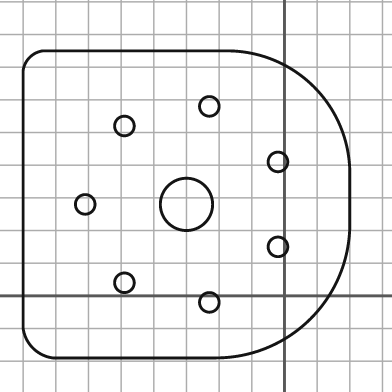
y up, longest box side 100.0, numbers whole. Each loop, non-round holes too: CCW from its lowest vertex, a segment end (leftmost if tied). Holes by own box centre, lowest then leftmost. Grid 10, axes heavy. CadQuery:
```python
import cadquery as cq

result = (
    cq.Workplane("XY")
    .moveTo(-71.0, -19.0)
    .lineTo(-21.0, -19.0)
    .threePointArc((8.0, -7.0), (20.0, 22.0))
    .lineTo(20.0, 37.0)
    .threePointArc((9.0, 64.0), (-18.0, 75.0))
    .lineTo(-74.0, 75.0)
    .threePointArc((-78.0, 73.0), (-80.0, 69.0))
    .lineTo(-80.0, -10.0)
    .threePointArc((-77.0, -16.0), (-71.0, -19.0))
    .close()
    .moveTo(-23.0, -2.0)
    .circle(3.0)
    .moveTo(-49.0, 4.0)
    .circle(3.0)
    .moveTo(-2.0, 15.0)
    .circle(3.0)
    .moveTo(-61.0, 28.0)
    .circle(3.0)
    .moveTo(-30.0, 28.0)
    .circle(8.0)
    .moveTo(-2.0, 41.0)
    .circle(3.0)
    .moveTo(-49.0, 52.0)
    .circle(3.0)
    .moveTo(-23.0, 58.0)
    .circle(3.0)
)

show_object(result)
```